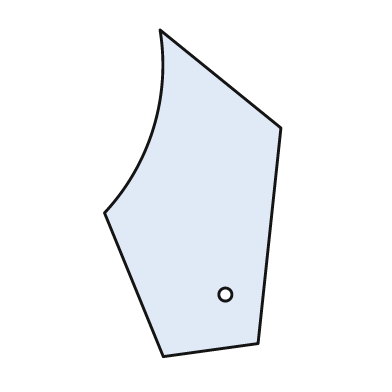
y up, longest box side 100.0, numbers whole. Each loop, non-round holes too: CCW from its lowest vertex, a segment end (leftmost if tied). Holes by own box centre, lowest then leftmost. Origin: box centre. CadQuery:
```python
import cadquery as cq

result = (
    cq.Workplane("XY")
    .moveTo(-9.0, -50.0)
    .lineTo(20.0, -46.0)
    .lineTo(27.0, 20.0)
    .lineTo(-10.0, 50.0)
    .threePointArc((-12.0, 20.0), (-27.0, -6.0))
    .close()
    .moveTo(10.0, -31.0)
    .circle(2.0)
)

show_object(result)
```